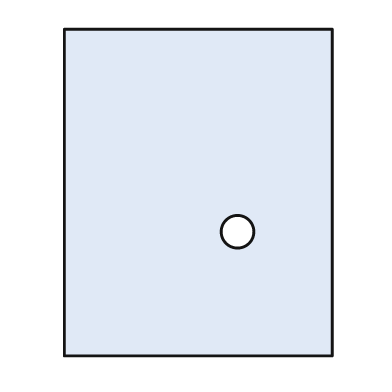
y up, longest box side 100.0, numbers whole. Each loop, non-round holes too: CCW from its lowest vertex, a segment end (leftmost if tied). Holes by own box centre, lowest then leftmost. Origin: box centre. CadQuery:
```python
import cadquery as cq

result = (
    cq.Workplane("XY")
    .moveTo(-41.0, -50.0)
    .lineTo(41.0, -50.0)
    .lineTo(41.0, 50.0)
    .lineTo(-41.0, 50.0)
    .close()
    .moveTo(12.0, -12.0)
    .circle(5.0)
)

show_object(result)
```